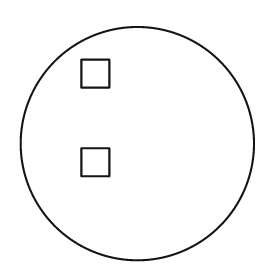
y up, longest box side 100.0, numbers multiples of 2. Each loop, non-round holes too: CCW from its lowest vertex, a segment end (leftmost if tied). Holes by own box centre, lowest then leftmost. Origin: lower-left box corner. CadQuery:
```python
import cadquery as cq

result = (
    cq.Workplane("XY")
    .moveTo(50.0, 50.0)
    .circle(50.0)
    .moveTo(26.0, 36.0)
    .lineTo(38.0, 36.0)
    .lineTo(38.0, 48.0)
    .lineTo(26.0, 48.0)
    .close()
    .moveTo(26.0, 74.0)
    .lineTo(38.0, 74.0)
    .lineTo(38.0, 86.0)
    .lineTo(26.0, 86.0)
    .close()
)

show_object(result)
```